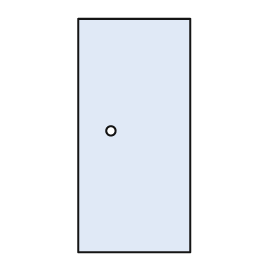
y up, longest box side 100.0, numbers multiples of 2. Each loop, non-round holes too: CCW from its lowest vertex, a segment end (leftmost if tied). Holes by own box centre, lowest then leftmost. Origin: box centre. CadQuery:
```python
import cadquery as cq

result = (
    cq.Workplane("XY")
    .moveTo(-24.0, -50.0)
    .lineTo(24.0, -50.0)
    .lineTo(24.0, 50.0)
    .lineTo(-24.0, 50.0)
    .close()
    .moveTo(-10.0, 2.0)
    .circle(2.0)
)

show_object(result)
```